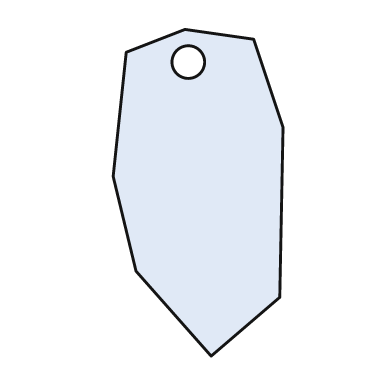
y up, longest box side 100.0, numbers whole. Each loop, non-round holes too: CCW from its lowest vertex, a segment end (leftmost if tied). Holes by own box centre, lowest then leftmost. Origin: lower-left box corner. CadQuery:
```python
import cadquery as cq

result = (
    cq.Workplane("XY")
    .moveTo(30.0, 0.0)
    .lineTo(51.0, 18.0)
    .lineTo(52.0, 70.0)
    .lineTo(43.0, 97.0)
    .lineTo(22.0, 100.0)
    .lineTo(4.0, 93.0)
    .lineTo(0.0, 55.0)
    .lineTo(7.0, 26.0)
    .close()
    .moveTo(23.0, 90.0)
    .circle(5.0)
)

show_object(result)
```